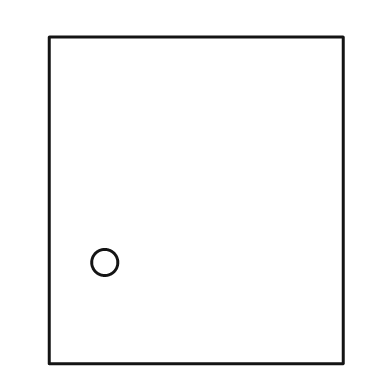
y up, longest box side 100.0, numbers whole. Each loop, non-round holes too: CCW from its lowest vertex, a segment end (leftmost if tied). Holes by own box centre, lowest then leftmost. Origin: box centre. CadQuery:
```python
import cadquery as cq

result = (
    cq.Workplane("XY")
    .moveTo(-45.0, -50.0)
    .lineTo(45.0, -50.0)
    .lineTo(45.0, 50.0)
    .lineTo(-45.0, 50.0)
    .close()
    .moveTo(-28.0, -19.0)
    .circle(4.0)
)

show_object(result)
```